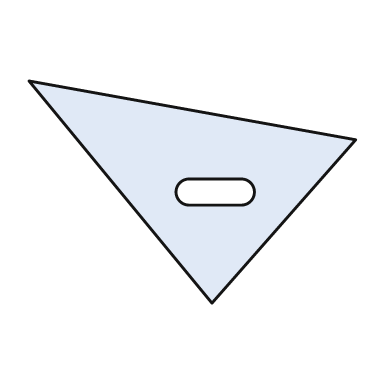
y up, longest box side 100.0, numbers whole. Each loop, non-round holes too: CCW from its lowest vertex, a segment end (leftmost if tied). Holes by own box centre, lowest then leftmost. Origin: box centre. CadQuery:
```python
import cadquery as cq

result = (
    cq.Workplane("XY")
    .moveTo(6.0, -34.0)
    .lineTo(50.0, 16.0)
    .lineTo(-50.0, 34.0)
    .close()
    .moveTo(-1.0, -4.0)
    .lineTo(15.0, -4.0)
    .threePointArc((19.0, 0.0), (15.0, 4.0))
    .lineTo(-1.0, 4.0)
    .threePointArc((-5.0, 0.0), (-1.0, -4.0))
    .close()
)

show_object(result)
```